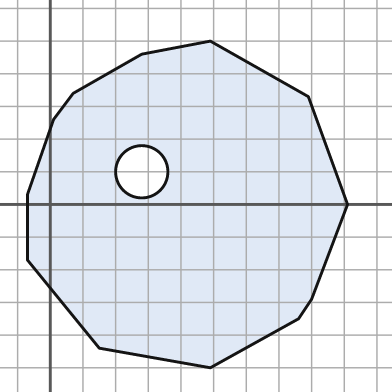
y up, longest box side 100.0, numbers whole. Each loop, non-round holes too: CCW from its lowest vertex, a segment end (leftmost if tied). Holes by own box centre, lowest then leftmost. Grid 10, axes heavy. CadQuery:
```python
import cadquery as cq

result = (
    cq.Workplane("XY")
    .moveTo(49.0, -50.0)
    .lineTo(76.0, -35.0)
    .lineTo(80.0, -29.0)
    .lineTo(91.0, 0.0)
    .lineTo(79.0, 33.0)
    .lineTo(49.0, 50.0)
    .lineTo(28.0, 46.0)
    .lineTo(7.0, 34.0)
    .lineTo(1.0, 26.0)
    .lineTo(-7.0, 3.0)
    .lineTo(-7.0, -17.0)
    .lineTo(15.0, -44.0)
    .close()
    .moveTo(28.0, 10.0)
    .circle(8.0)
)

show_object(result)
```